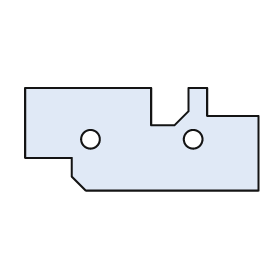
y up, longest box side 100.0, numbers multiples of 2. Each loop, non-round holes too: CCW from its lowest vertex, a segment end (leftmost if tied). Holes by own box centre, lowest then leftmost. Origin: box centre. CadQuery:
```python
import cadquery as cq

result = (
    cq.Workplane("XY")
    .moveTo(-24.0, -22.0)
    .lineTo(50.0, -22.0)
    .lineTo(50.0, 10.0)
    .lineTo(28.0, 10.0)
    .lineTo(28.0, 22.0)
    .lineTo(20.0, 22.0)
    .lineTo(20.0, 12.0)
    .lineTo(14.0, 6.0)
    .lineTo(4.0, 6.0)
    .lineTo(4.0, 22.0)
    .lineTo(-50.0, 22.0)
    .lineTo(-50.0, -8.0)
    .lineTo(-30.0, -8.0)
    .lineTo(-30.0, -16.0)
    .close()
    .moveTo(-22.0, 0.0)
    .circle(4.0)
    .moveTo(22.0, 0.0)
    .circle(4.0)
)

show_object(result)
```